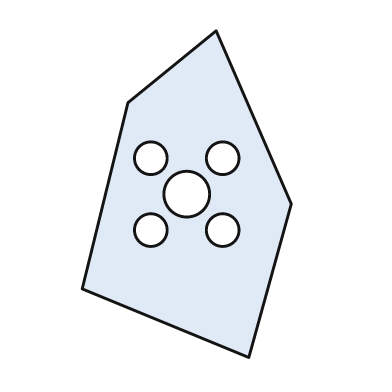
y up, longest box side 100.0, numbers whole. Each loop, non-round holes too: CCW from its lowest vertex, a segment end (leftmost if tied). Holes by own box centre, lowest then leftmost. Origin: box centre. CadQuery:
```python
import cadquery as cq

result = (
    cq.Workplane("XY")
    .moveTo(19.0, -50.0)
    .lineTo(32.0, -3.0)
    .lineTo(9.0, 50.0)
    .lineTo(-18.0, 28.0)
    .lineTo(-32.0, -29.0)
    .close()
    .moveTo(-11.0, -11.0)
    .circle(5.0)
    .moveTo(11.0, -11.0)
    .circle(5.0)
    .moveTo(0.0, 0.0)
    .circle(7.0)
    .moveTo(-11.0, 11.0)
    .circle(5.0)
    .moveTo(11.0, 11.0)
    .circle(5.0)
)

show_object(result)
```